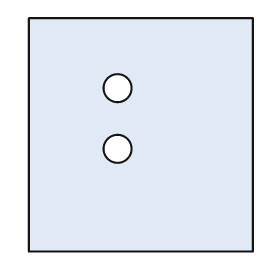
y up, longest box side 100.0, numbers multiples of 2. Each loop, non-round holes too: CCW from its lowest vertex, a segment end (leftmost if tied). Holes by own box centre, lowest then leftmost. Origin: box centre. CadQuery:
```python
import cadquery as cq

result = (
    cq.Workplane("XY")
    .moveTo(-48.0, -50.0)
    .lineTo(48.0, -50.0)
    .lineTo(48.0, 50.0)
    .lineTo(-48.0, 50.0)
    .close()
    .moveTo(-10.0, -6.0)
    .circle(6.0)
    .moveTo(-10.0, 20.0)
    .circle(6.0)
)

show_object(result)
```